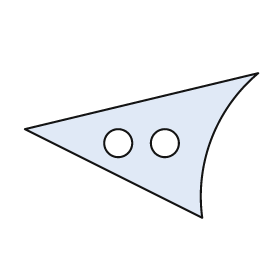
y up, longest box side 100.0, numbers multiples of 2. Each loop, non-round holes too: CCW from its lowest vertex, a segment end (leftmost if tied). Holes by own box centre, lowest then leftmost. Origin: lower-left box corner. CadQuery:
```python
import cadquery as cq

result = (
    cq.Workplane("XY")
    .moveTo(76.0, 0.0)
    .threePointArc((80.0, 34.0), (100.0, 62.0))
    .lineTo(0.0, 38.0)
    .close()
    .moveTo(40.0, 32.0)
    .circle(6.0)
    .moveTo(60.0, 32.0)
    .circle(6.0)
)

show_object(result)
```